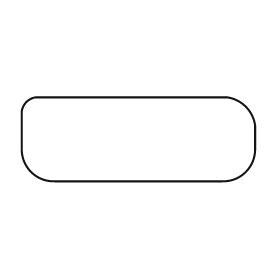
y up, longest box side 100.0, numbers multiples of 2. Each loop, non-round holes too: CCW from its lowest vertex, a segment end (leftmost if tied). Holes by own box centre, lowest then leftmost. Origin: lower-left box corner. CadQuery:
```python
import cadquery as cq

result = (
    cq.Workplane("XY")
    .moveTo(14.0, 0.0)
    .lineTo(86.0, 0.0)
    .threePointArc((96.0, 4.0), (100.0, 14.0))
    .lineTo(100.0, 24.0)
    .threePointArc((96.0, 32.0), (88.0, 36.0))
    .lineTo(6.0, 36.0)
    .threePointArc((2.0, 34.0), (0.0, 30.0))
    .lineTo(0.0, 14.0)
    .threePointArc((4.0, 4.0), (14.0, 0.0))
    .close()
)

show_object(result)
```